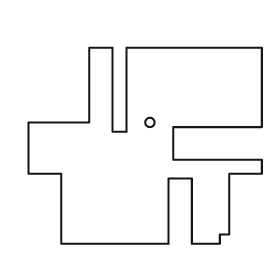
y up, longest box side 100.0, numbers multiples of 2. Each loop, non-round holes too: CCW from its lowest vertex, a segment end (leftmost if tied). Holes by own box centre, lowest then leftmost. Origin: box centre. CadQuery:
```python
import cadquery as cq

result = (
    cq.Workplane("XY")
    .moveTo(-36.0, -42.0)
    .lineTo(10.0, -42.0)
    .lineTo(10.0, -14.0)
    .lineTo(20.0, -14.0)
    .lineTo(20.0, -42.0)
    .lineTo(32.0, -42.0)
    .lineTo(32.0, -38.0)
    .lineTo(36.0, -38.0)
    .lineTo(36.0, -12.0)
    .lineTo(50.0, -12.0)
    .lineTo(50.0, -6.0)
    .lineTo(12.0, -6.0)
    .lineTo(12.0, 8.0)
    .lineTo(50.0, 8.0)
    .lineTo(50.0, 42.0)
    .lineTo(-8.0, 42.0)
    .lineTo(-8.0, 6.0)
    .lineTo(-14.0, 6.0)
    .lineTo(-14.0, 42.0)
    .lineTo(-24.0, 42.0)
    .lineTo(-24.0, 10.0)
    .lineTo(-50.0, 10.0)
    .lineTo(-50.0, -12.0)
    .lineTo(-36.0, -12.0)
    .close()
    .moveTo(2.0, 10.0)
    .circle(2.0)
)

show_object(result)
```